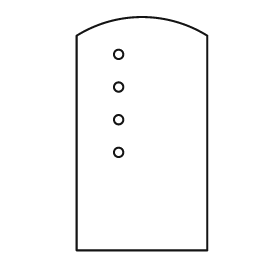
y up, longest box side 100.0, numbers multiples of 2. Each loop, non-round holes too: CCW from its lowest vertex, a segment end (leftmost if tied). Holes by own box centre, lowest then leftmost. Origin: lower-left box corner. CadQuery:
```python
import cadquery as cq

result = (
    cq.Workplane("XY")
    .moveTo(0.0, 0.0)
    .lineTo(56.0, 0.0)
    .lineTo(56.0, 92.0)
    .threePointArc((28.0, 100.0), (0.0, 92.0))
    .close()
    .moveTo(18.0, 42.0)
    .circle(2.0)
    .moveTo(18.0, 56.0)
    .circle(2.0)
    .moveTo(18.0, 70.0)
    .circle(2.0)
    .moveTo(18.0, 84.0)
    .circle(2.0)
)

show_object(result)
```